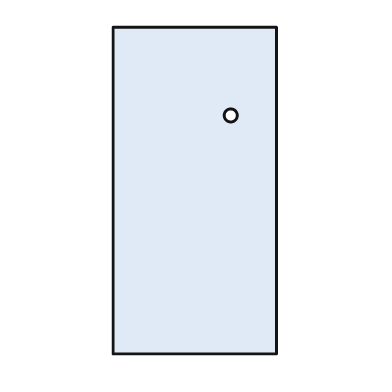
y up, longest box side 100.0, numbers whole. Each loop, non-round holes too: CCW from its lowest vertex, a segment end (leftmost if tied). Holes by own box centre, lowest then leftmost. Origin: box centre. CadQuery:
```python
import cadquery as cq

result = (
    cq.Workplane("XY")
    .moveTo(-25.0, -50.0)
    .lineTo(25.0, -50.0)
    .lineTo(25.0, 50.0)
    .lineTo(-25.0, 50.0)
    .close()
    .moveTo(11.0, 23.0)
    .circle(2.0)
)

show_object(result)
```